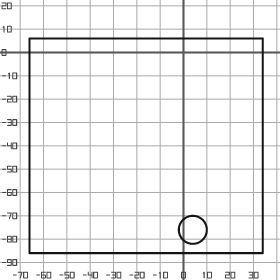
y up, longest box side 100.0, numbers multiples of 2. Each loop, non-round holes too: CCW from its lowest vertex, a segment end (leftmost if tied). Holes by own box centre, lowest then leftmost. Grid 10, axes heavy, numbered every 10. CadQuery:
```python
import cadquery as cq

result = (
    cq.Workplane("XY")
    .moveTo(-66.0, -86.0)
    .lineTo(34.0, -86.0)
    .lineTo(34.0, 6.0)
    .lineTo(-66.0, 6.0)
    .close()
    .moveTo(4.0, -76.0)
    .circle(6.0)
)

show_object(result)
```